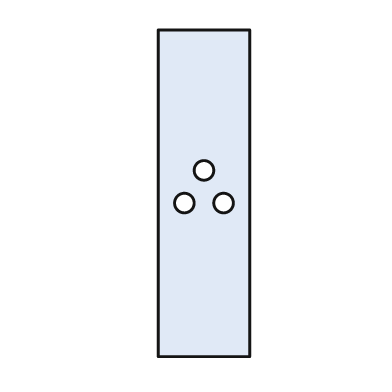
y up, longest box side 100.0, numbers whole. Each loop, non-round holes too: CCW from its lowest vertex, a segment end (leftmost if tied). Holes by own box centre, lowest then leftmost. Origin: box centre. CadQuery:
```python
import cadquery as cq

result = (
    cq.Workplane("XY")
    .moveTo(-14.0, -50.0)
    .lineTo(14.0, -50.0)
    .lineTo(14.0, 50.0)
    .lineTo(-14.0, 50.0)
    .close()
    .moveTo(-6.0, -3.0)
    .circle(3.0)
    .moveTo(6.0, -3.0)
    .circle(3.0)
    .moveTo(0.0, 7.0)
    .circle(3.0)
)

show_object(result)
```